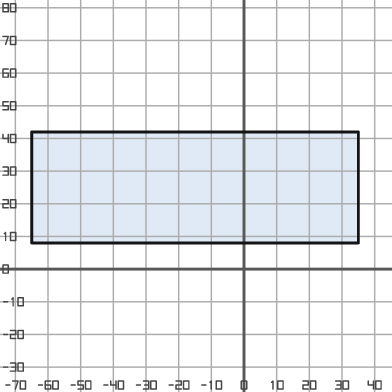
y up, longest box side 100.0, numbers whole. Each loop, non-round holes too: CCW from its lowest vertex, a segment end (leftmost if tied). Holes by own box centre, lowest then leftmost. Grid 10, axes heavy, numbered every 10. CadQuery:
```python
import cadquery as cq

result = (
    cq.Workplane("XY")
    .moveTo(-65.0, 8.0)
    .lineTo(35.0, 8.0)
    .lineTo(35.0, 42.0)
    .lineTo(-65.0, 42.0)
    .close()
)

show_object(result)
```